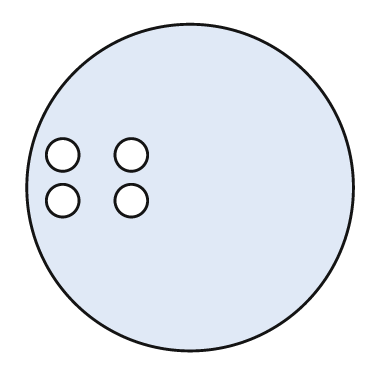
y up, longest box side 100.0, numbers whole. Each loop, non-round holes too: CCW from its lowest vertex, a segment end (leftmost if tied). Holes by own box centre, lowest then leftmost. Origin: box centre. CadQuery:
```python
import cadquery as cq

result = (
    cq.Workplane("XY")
    .moveTo(0.0, 0.0)
    .circle(50.0)
    .moveTo(-39.0, -4.0)
    .circle(5.0)
    .moveTo(-18.0, -4.0)
    .circle(5.0)
    .moveTo(-39.0, 10.0)
    .circle(5.0)
    .moveTo(-18.0, 10.0)
    .circle(5.0)
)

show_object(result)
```